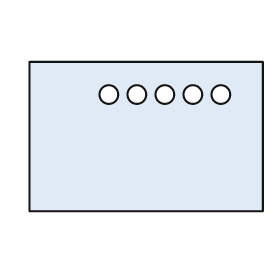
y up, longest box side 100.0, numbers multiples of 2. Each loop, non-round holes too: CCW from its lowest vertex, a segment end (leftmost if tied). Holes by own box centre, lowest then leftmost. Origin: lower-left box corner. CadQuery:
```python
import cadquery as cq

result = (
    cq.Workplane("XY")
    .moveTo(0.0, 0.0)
    .lineTo(100.0, 0.0)
    .lineTo(100.0, 64.0)
    .lineTo(0.0, 64.0)
    .close()
    .moveTo(34.0, 50.0)
    .circle(4.0)
    .moveTo(46.0, 50.0)
    .circle(4.0)
    .moveTo(58.0, 50.0)
    .circle(4.0)
    .moveTo(70.0, 50.0)
    .circle(4.0)
    .moveTo(82.0, 50.0)
    .circle(4.0)
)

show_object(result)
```